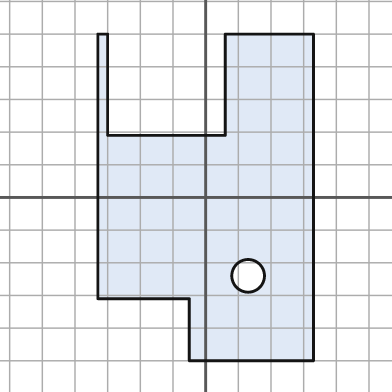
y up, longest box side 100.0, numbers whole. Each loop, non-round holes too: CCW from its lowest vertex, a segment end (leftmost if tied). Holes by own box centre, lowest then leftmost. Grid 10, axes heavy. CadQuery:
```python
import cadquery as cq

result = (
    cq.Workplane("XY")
    .moveTo(-5.0, -50.0)
    .lineTo(33.0, -50.0)
    .lineTo(33.0, 50.0)
    .lineTo(6.0, 50.0)
    .lineTo(6.0, 19.0)
    .lineTo(-30.0, 19.0)
    .lineTo(-30.0, 50.0)
    .lineTo(-33.0, 50.0)
    .lineTo(-33.0, -31.0)
    .lineTo(-5.0, -31.0)
    .close()
    .moveTo(13.0, -24.0)
    .circle(5.0)
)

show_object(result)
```